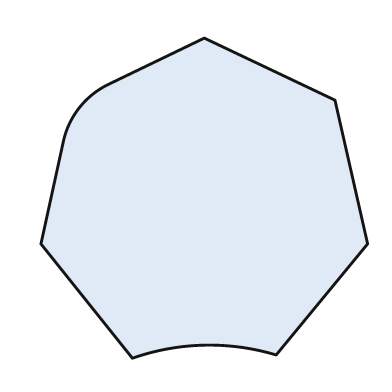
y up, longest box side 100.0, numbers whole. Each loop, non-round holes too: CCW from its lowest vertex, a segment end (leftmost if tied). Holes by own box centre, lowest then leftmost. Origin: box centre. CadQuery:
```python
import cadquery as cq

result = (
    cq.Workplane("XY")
    .moveTo(-22.0, -49.0)
    .threePointArc((0.0, -45.0), (22.0, -48.0))
    .lineTo(50.0, -14.0)
    .lineTo(40.0, 30.0)
    .lineTo(0.0, 49.0)
    .lineTo(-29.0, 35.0)
    .threePointArc((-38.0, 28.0), (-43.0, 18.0))
    .lineTo(-50.0, -14.0)
    .close()
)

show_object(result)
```